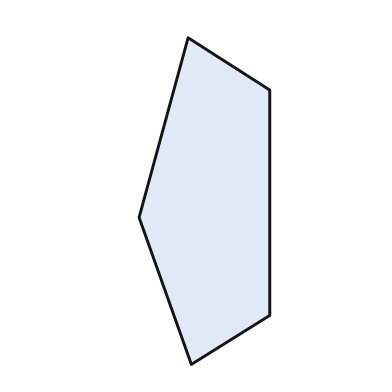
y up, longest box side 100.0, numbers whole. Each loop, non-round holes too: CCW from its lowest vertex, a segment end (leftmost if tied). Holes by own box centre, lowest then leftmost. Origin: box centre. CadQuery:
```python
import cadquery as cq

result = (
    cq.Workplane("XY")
    .moveTo(-4.0, -50.0)
    .lineTo(20.0, -35.0)
    .lineTo(20.0, 34.0)
    .lineTo(-5.0, 50.0)
    .lineTo(-20.0, -5.0)
    .close()
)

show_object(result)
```